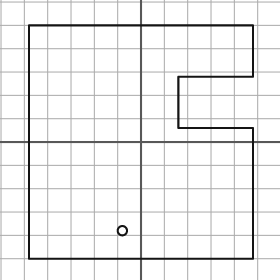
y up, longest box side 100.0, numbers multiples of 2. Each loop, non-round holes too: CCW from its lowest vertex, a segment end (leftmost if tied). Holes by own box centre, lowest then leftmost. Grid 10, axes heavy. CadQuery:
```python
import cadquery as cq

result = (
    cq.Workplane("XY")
    .moveTo(-48.0, -50.0)
    .lineTo(48.0, -50.0)
    .lineTo(48.0, 6.0)
    .lineTo(16.0, 6.0)
    .lineTo(16.0, 28.0)
    .lineTo(48.0, 28.0)
    .lineTo(48.0, 50.0)
    .lineTo(-48.0, 50.0)
    .close()
    .moveTo(-8.0, -38.0)
    .circle(2.0)
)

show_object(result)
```